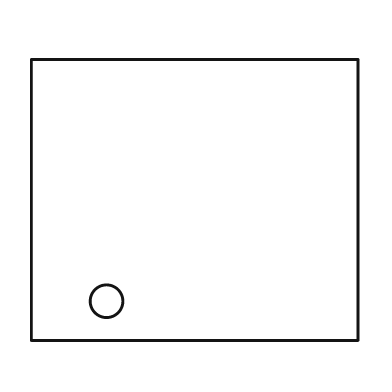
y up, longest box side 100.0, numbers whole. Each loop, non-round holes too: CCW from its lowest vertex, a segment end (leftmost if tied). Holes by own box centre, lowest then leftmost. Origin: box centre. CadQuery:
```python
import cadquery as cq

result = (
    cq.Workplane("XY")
    .moveTo(-50.0, -43.0)
    .lineTo(50.0, -43.0)
    .lineTo(50.0, 43.0)
    .lineTo(-50.0, 43.0)
    .close()
    .moveTo(-27.0, -31.0)
    .circle(5.0)
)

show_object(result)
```